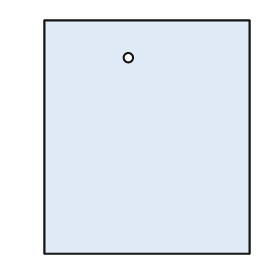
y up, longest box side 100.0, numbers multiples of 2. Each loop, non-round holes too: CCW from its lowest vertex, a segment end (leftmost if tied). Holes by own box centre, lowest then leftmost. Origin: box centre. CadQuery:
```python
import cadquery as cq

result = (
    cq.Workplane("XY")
    .moveTo(-44.0, -50.0)
    .lineTo(44.0, -50.0)
    .lineTo(44.0, 50.0)
    .lineTo(-44.0, 50.0)
    .close()
    .moveTo(-8.0, 34.0)
    .circle(2.0)
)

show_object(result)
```